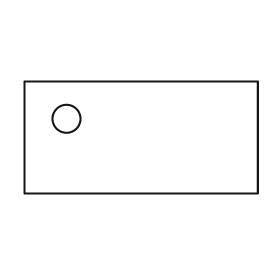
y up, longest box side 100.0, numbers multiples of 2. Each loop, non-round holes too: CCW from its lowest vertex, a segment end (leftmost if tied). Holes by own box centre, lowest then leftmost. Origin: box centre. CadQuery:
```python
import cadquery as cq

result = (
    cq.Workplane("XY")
    .moveTo(-50.0, -24.0)
    .lineTo(50.0, -24.0)
    .lineTo(50.0, 24.0)
    .lineTo(-50.0, 24.0)
    .close()
    .moveTo(-32.0, 8.0)
    .circle(6.0)
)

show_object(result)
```